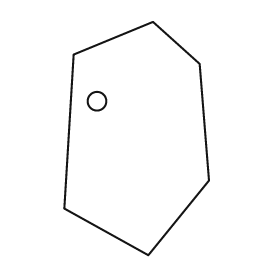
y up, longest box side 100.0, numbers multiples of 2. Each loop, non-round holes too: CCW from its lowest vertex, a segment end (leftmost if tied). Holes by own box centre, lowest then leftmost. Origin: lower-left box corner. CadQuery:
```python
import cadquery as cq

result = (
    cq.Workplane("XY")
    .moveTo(36.0, 0.0)
    .lineTo(62.0, 32.0)
    .lineTo(58.0, 82.0)
    .lineTo(38.0, 100.0)
    .lineTo(4.0, 86.0)
    .lineTo(0.0, 20.0)
    .close()
    .moveTo(14.0, 66.0)
    .circle(4.0)
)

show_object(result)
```